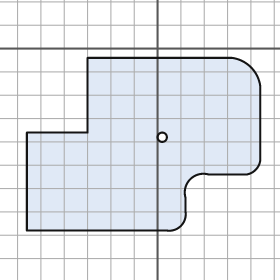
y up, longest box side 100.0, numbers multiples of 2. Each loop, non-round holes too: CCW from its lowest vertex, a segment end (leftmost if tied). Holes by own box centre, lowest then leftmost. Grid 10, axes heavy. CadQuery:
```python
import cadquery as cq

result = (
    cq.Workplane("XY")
    .moveTo(-56.0, -78.0)
    .lineTo(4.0, -78.0)
    .threePointArc((10.0, -76.0), (12.0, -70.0))
    .lineTo(12.0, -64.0)
    .threePointArc((14.0, -56.0), (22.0, -54.0))
    .lineTo(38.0, -54.0)
    .threePointArc((42.0, -52.0), (44.0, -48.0))
    .lineTo(44.0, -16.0)
    .threePointArc((40.0, -8.0), (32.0, -4.0))
    .lineTo(-30.0, -4.0)
    .lineTo(-30.0, -36.0)
    .lineTo(-56.0, -36.0)
    .close()
    .moveTo(2.0, -38.0)
    .circle(2.0)
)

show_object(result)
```